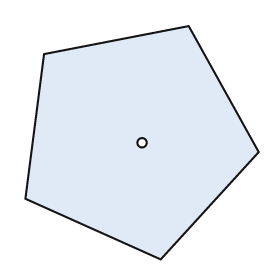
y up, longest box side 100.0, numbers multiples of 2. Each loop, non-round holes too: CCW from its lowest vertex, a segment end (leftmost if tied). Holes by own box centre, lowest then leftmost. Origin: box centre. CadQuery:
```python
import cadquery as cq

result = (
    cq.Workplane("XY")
    .moveTo(8.0, -50.0)
    .lineTo(50.0, -4.0)
    .lineTo(20.0, 50.0)
    .lineTo(-42.0, 38.0)
    .lineTo(-50.0, -24.0)
    .close()
    .moveTo(0.0, 0.0)
    .circle(2.0)
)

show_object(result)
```